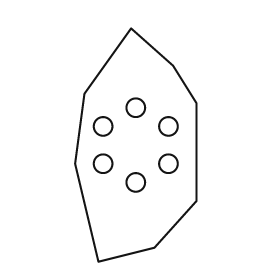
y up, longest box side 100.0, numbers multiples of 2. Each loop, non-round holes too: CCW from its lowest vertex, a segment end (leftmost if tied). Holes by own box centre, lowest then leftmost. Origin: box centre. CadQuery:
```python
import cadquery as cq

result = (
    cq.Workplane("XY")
    .moveTo(-16.0, -50.0)
    .lineTo(8.0, -44.0)
    .lineTo(26.0, -24.0)
    .lineTo(26.0, 18.0)
    .lineTo(16.0, 34.0)
    .lineTo(-2.0, 50.0)
    .lineTo(-22.0, 22.0)
    .lineTo(-26.0, -8.0)
    .close()
    .moveTo(0.0, -16.0)
    .circle(4.0)
    .moveTo(-14.0, -8.0)
    .circle(4.0)
    .moveTo(14.0, -8.0)
    .circle(4.0)
    .moveTo(-14.0, 8.0)
    .circle(4.0)
    .moveTo(14.0, 8.0)
    .circle(4.0)
    .moveTo(0.0, 16.0)
    .circle(4.0)
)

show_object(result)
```